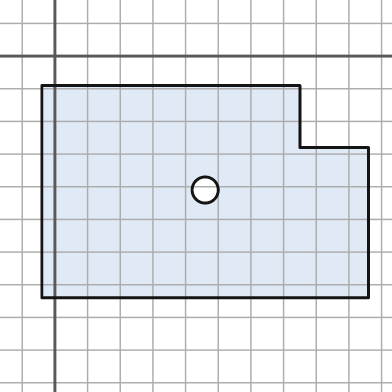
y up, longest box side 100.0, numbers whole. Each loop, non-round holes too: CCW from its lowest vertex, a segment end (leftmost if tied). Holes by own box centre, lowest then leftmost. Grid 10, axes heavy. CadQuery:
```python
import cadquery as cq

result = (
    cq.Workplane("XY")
    .moveTo(-4.0, -74.0)
    .lineTo(96.0, -74.0)
    .lineTo(96.0, -28.0)
    .lineTo(75.0, -28.0)
    .lineTo(75.0, -9.0)
    .lineTo(-4.0, -9.0)
    .close()
    .moveTo(46.0, -41.0)
    .circle(4.0)
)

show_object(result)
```